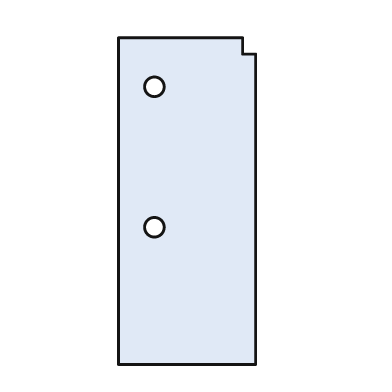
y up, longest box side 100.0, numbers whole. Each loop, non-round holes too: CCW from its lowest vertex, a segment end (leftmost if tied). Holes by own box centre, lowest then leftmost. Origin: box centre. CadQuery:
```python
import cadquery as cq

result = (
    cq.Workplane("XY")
    .moveTo(-21.0, -50.0)
    .lineTo(21.0, -50.0)
    .lineTo(21.0, 45.0)
    .lineTo(17.0, 45.0)
    .lineTo(17.0, 50.0)
    .lineTo(-21.0, 50.0)
    .close()
    .moveTo(-10.0, -8.0)
    .circle(3.0)
    .moveTo(-10.0, 35.0)
    .circle(3.0)
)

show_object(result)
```